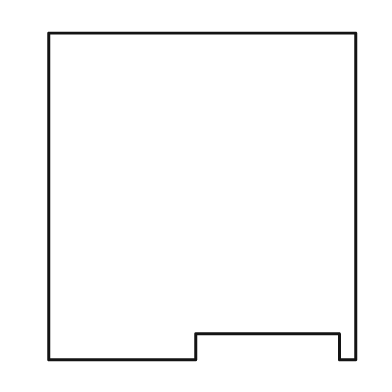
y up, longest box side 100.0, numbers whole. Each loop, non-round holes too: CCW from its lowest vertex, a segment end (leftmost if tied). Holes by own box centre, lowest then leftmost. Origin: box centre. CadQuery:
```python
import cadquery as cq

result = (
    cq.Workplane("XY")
    .moveTo(-47.0, -50.0)
    .lineTo(-2.0, -50.0)
    .lineTo(-2.0, -42.0)
    .lineTo(42.0, -42.0)
    .lineTo(42.0, -50.0)
    .lineTo(47.0, -50.0)
    .lineTo(47.0, 50.0)
    .lineTo(-47.0, 50.0)
    .close()
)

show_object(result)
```